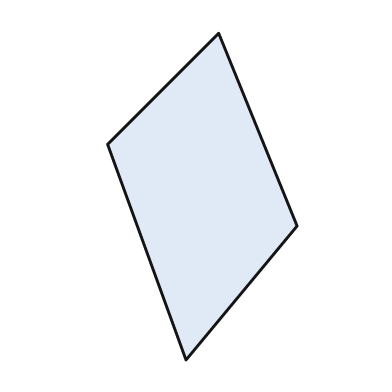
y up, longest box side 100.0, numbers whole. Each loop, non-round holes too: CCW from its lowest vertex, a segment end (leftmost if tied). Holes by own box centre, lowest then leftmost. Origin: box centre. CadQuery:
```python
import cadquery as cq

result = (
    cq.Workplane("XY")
    .moveTo(-5.0, -50.0)
    .lineTo(29.0, -9.0)
    .lineTo(5.0, 50.0)
    .lineTo(-29.0, 16.0)
    .close()
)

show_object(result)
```